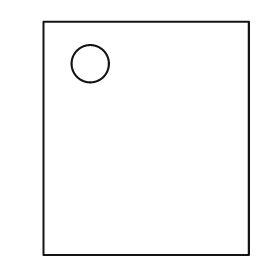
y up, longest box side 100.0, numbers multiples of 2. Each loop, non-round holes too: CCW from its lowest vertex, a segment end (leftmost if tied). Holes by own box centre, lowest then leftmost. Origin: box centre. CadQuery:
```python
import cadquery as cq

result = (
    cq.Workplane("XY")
    .moveTo(-44.0, -50.0)
    .lineTo(44.0, -50.0)
    .lineTo(44.0, 50.0)
    .lineTo(-44.0, 50.0)
    .close()
    .moveTo(-24.0, 32.0)
    .circle(8.0)
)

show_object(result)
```